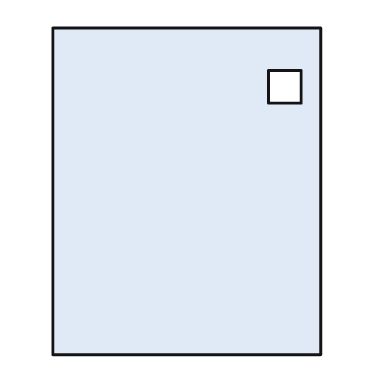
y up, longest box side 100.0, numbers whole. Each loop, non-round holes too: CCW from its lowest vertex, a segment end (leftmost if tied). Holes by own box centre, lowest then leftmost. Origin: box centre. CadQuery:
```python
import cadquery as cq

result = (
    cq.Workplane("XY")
    .moveTo(-41.0, -50.0)
    .lineTo(41.0, -50.0)
    .lineTo(41.0, 50.0)
    .lineTo(-41.0, 50.0)
    .close()
    .moveTo(25.0, 27.0)
    .lineTo(35.0, 27.0)
    .lineTo(35.0, 37.0)
    .lineTo(25.0, 37.0)
    .close()
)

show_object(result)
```